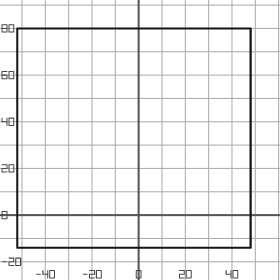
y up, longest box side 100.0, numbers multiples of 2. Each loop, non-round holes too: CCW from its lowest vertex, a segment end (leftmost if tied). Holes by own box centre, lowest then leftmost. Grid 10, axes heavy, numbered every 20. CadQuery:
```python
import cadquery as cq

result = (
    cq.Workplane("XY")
    .moveTo(-52.0, -14.0)
    .lineTo(48.0, -14.0)
    .lineTo(48.0, 80.0)
    .lineTo(-52.0, 80.0)
    .close()
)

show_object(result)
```